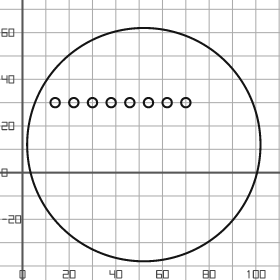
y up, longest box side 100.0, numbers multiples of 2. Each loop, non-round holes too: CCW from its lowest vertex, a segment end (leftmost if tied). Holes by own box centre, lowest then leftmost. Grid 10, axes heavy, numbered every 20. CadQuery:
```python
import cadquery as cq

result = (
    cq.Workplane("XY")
    .moveTo(52.0, 12.0)
    .circle(50.0)
    .moveTo(14.0, 30.0)
    .circle(2.0)
    .moveTo(22.0, 30.0)
    .circle(2.0)
    .moveTo(30.0, 30.0)
    .circle(2.0)
    .moveTo(38.0, 30.0)
    .circle(2.0)
    .moveTo(46.0, 30.0)
    .circle(2.0)
    .moveTo(54.0, 30.0)
    .circle(2.0)
    .moveTo(62.0, 30.0)
    .circle(2.0)
    .moveTo(70.0, 30.0)
    .circle(2.0)
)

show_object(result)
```